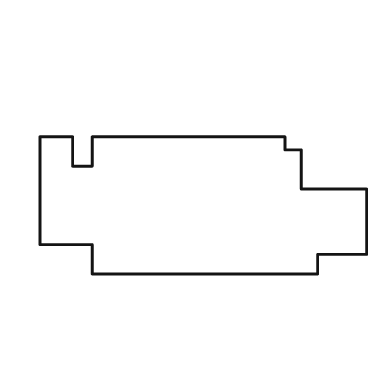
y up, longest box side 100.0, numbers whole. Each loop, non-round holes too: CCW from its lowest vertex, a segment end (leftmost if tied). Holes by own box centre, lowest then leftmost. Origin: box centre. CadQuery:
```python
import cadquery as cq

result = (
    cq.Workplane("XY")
    .moveTo(-34.0, -21.0)
    .lineTo(35.0, -21.0)
    .lineTo(35.0, -15.0)
    .lineTo(50.0, -15.0)
    .lineTo(50.0, 5.0)
    .lineTo(30.0, 5.0)
    .lineTo(30.0, 17.0)
    .lineTo(25.0, 17.0)
    .lineTo(25.0, 21.0)
    .lineTo(-34.0, 21.0)
    .lineTo(-34.0, 12.0)
    .lineTo(-40.0, 12.0)
    .lineTo(-40.0, 21.0)
    .lineTo(-50.0, 21.0)
    .lineTo(-50.0, -12.0)
    .lineTo(-34.0, -12.0)
    .close()
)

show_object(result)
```